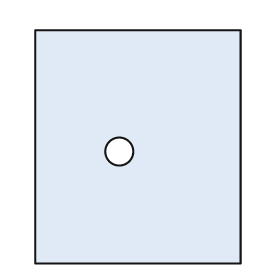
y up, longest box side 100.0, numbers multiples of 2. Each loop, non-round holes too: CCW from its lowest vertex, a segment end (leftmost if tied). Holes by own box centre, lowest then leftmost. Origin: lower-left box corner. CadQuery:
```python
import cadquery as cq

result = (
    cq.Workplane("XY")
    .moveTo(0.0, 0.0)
    .lineTo(88.0, 0.0)
    .lineTo(88.0, 100.0)
    .lineTo(0.0, 100.0)
    .close()
    .moveTo(36.0, 48.0)
    .circle(6.0)
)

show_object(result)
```